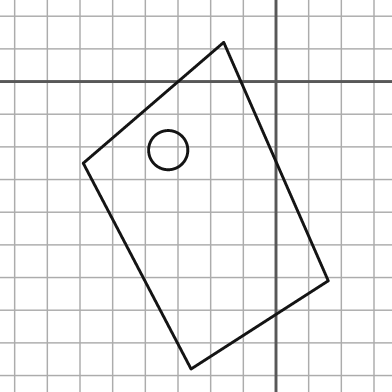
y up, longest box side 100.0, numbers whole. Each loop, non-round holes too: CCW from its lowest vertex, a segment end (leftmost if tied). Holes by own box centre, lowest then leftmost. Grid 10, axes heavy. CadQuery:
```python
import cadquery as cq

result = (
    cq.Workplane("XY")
    .moveTo(-26.0, -88.0)
    .lineTo(16.0, -61.0)
    .lineTo(-16.0, 12.0)
    .lineTo(-59.0, -25.0)
    .close()
    .moveTo(-33.0, -21.0)
    .circle(6.0)
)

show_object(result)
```